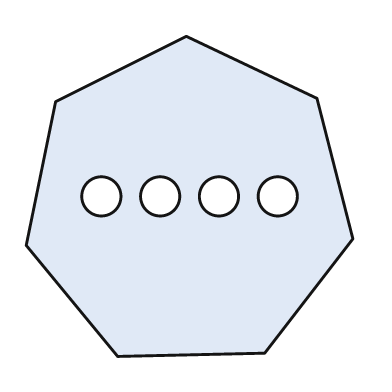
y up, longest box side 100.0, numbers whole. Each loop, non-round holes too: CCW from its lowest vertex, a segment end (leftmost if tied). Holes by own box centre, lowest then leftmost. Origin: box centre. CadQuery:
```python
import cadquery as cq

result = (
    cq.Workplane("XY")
    .moveTo(-22.0, -49.0)
    .lineTo(23.0, -48.0)
    .lineTo(50.0, -13.0)
    .lineTo(39.0, 30.0)
    .lineTo(-1.0, 49.0)
    .lineTo(-41.0, 29.0)
    .lineTo(-50.0, -15.0)
    .close()
    .moveTo(-27.0, 0.0)
    .circle(6.0)
    .moveTo(-9.0, 0.0)
    .circle(6.0)
    .moveTo(9.0, 0.0)
    .circle(6.0)
    .moveTo(27.0, 0.0)
    .circle(6.0)
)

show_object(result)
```